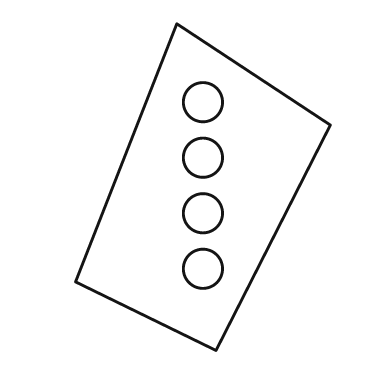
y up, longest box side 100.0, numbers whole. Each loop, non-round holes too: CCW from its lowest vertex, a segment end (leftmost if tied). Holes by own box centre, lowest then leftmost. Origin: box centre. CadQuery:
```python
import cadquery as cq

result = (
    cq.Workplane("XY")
    .moveTo(4.0, -50.0)
    .lineTo(39.0, 19.0)
    .lineTo(-8.0, 50.0)
    .lineTo(-39.0, -29.0)
    .close()
    .moveTo(0.0, -25.0)
    .circle(6.0)
    .moveTo(0.0, -8.0)
    .circle(6.0)
    .moveTo(0.0, 9.0)
    .circle(6.0)
    .moveTo(0.0, 26.0)
    .circle(6.0)
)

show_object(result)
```